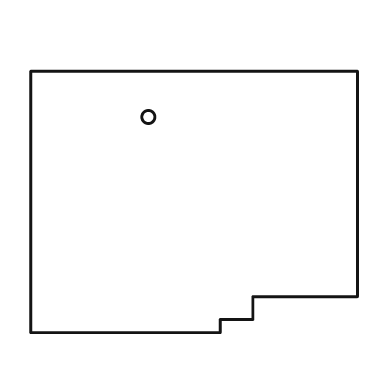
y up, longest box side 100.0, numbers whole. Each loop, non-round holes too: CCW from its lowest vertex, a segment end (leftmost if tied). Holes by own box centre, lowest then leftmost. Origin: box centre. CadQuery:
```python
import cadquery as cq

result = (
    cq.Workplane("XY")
    .moveTo(-50.0, -40.0)
    .lineTo(8.0, -40.0)
    .lineTo(8.0, -36.0)
    .lineTo(18.0, -36.0)
    .lineTo(18.0, -29.0)
    .lineTo(50.0, -29.0)
    .lineTo(50.0, 40.0)
    .lineTo(-50.0, 40.0)
    .close()
    .moveTo(-14.0, 26.0)
    .circle(2.0)
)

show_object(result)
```